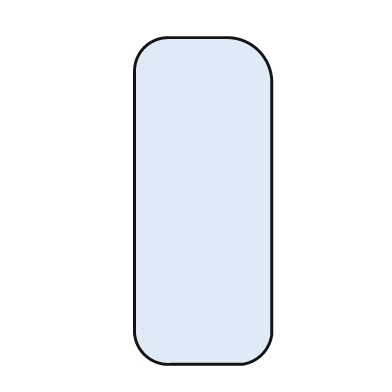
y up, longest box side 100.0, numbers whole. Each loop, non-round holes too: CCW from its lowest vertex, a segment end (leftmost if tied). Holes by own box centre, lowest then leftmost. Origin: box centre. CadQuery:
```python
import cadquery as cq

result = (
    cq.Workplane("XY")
    .moveTo(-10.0, -50.0)
    .lineTo(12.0, -50.0)
    .threePointArc((18.0, -47.0), (21.0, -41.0))
    .lineTo(21.0, 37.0)
    .threePointArc((17.0, 46.0), (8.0, 50.0))
    .lineTo(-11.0, 50.0)
    .threePointArc((-18.0, 47.0), (-21.0, 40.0))
    .lineTo(-21.0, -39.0)
    .threePointArc((-18.0, -47.0), (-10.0, -50.0))
    .close()
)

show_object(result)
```